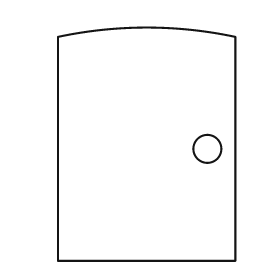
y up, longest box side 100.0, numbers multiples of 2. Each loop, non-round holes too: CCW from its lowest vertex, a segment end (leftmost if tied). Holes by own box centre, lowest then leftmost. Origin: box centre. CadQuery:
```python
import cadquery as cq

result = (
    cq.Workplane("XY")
    .moveTo(-38.0, -50.0)
    .lineTo(38.0, -50.0)
    .lineTo(38.0, 46.0)
    .threePointArc((0.0, 50.0), (-38.0, 46.0))
    .close()
    .moveTo(26.0, -2.0)
    .circle(6.0)
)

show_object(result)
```